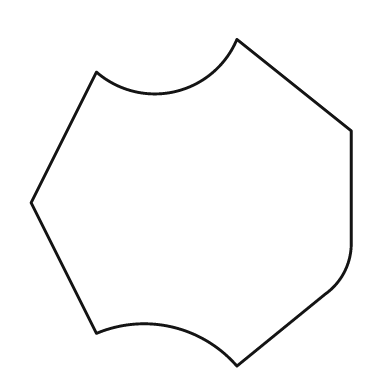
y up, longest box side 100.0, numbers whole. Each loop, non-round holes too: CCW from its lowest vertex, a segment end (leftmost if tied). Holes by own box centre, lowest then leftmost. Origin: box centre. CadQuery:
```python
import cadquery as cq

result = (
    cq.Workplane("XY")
    .moveTo(14.0, -50.0)
    .lineTo(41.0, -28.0)
    .threePointArc((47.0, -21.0), (49.0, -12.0))
    .lineTo(49.0, 22.0)
    .lineTo(14.0, 50.0)
    .threePointArc((-5.0, 34.0), (-29.0, 40.0))
    .lineTo(-49.0, 0.0)
    .lineTo(-29.0, -40.0)
    .threePointArc((-6.0, -38.0), (14.0, -50.0))
    .close()
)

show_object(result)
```